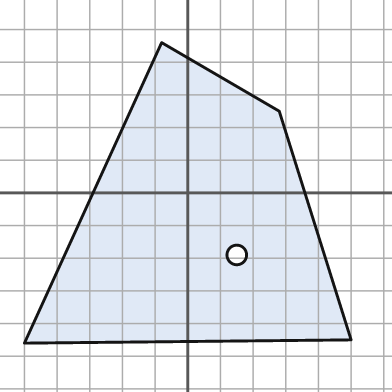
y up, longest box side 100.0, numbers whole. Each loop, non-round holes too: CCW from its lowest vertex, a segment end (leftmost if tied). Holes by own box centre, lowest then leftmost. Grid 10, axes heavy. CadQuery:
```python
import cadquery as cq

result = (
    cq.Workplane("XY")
    .moveTo(-50.0, -46.0)
    .lineTo(50.0, -45.0)
    .lineTo(28.0, 25.0)
    .lineTo(-8.0, 46.0)
    .close()
    .moveTo(15.0, -19.0)
    .circle(3.0)
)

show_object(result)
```